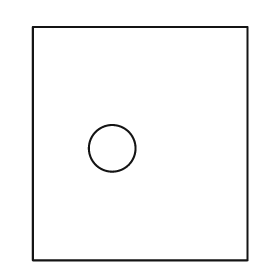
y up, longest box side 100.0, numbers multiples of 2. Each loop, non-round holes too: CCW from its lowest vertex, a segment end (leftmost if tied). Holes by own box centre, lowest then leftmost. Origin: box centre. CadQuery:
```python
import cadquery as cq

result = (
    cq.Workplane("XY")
    .moveTo(-46.0, -50.0)
    .lineTo(46.0, -50.0)
    .lineTo(46.0, 50.0)
    .lineTo(-46.0, 50.0)
    .close()
    .moveTo(-12.0, -2.0)
    .circle(10.0)
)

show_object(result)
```